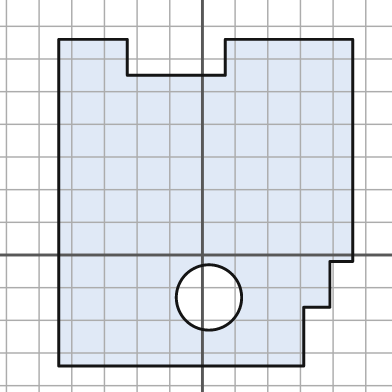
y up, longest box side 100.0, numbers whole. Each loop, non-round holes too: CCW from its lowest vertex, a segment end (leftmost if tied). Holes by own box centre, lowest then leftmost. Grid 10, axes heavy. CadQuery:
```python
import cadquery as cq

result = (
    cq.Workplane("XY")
    .moveTo(-44.0, -34.0)
    .lineTo(31.0, -34.0)
    .lineTo(31.0, -16.0)
    .lineTo(39.0, -16.0)
    .lineTo(39.0, -2.0)
    .lineTo(46.0, -2.0)
    .lineTo(46.0, 66.0)
    .lineTo(7.0, 66.0)
    .lineTo(7.0, 55.0)
    .lineTo(-23.0, 55.0)
    .lineTo(-23.0, 66.0)
    .lineTo(-44.0, 66.0)
    .close()
    .moveTo(2.0, -13.0)
    .circle(10.0)
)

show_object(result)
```